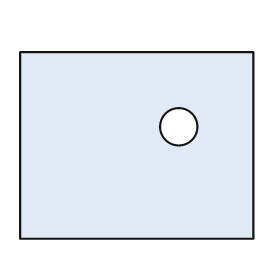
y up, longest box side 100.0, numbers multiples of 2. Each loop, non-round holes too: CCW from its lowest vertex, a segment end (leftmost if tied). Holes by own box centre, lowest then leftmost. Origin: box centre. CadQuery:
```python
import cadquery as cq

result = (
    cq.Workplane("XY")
    .moveTo(-50.0, -40.0)
    .lineTo(50.0, -40.0)
    .lineTo(50.0, 40.0)
    .lineTo(-50.0, 40.0)
    .close()
    .moveTo(18.0, 8.0)
    .circle(8.0)
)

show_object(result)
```